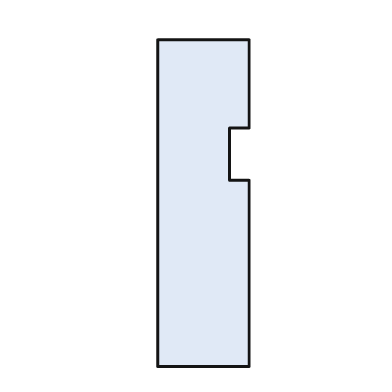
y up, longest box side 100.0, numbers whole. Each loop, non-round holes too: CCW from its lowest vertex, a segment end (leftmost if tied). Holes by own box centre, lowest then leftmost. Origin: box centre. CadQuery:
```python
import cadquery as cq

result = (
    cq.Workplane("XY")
    .moveTo(-14.0, -50.0)
    .lineTo(14.0, -50.0)
    .lineTo(14.0, 7.0)
    .lineTo(8.0, 7.0)
    .lineTo(8.0, 23.0)
    .lineTo(14.0, 23.0)
    .lineTo(14.0, 50.0)
    .lineTo(-14.0, 50.0)
    .close()
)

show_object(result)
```